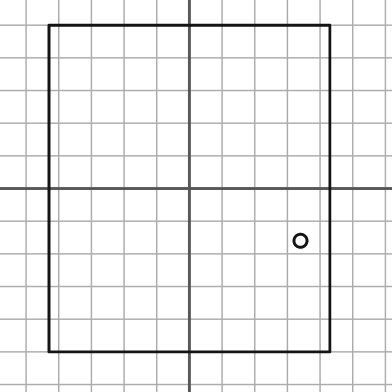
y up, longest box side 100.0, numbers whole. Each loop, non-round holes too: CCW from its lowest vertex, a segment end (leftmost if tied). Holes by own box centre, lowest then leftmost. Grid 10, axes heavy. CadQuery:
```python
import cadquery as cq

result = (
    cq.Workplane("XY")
    .moveTo(-43.0, -50.0)
    .lineTo(43.0, -50.0)
    .lineTo(43.0, 50.0)
    .lineTo(-43.0, 50.0)
    .close()
    .moveTo(34.0, -16.0)
    .circle(2.0)
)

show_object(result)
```